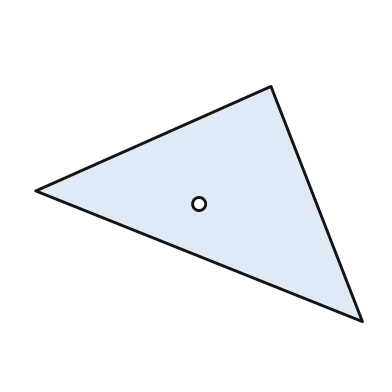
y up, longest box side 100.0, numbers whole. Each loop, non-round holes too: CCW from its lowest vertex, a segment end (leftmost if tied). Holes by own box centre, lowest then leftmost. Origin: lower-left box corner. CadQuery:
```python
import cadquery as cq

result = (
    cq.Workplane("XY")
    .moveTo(100.0, 0.0)
    .lineTo(72.0, 72.0)
    .lineTo(0.0, 40.0)
    .close()
    .moveTo(50.0, 36.0)
    .circle(2.0)
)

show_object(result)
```